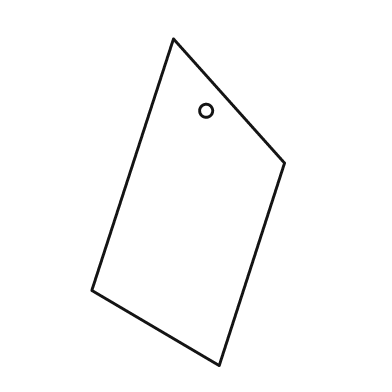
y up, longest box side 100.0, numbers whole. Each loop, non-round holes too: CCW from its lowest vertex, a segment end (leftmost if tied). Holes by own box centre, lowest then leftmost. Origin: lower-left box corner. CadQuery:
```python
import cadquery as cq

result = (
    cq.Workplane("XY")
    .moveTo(39.0, 0.0)
    .lineTo(59.0, 62.0)
    .lineTo(25.0, 100.0)
    .lineTo(0.0, 23.0)
    .close()
    .moveTo(35.0, 78.0)
    .circle(2.0)
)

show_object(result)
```